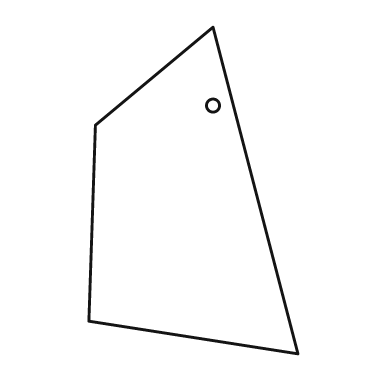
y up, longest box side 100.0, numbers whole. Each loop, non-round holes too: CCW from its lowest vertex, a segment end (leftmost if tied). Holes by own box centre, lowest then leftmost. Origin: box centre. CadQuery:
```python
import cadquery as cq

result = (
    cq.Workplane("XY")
    .moveTo(32.0, -50.0)
    .lineTo(6.0, 50.0)
    .lineTo(-30.0, 20.0)
    .lineTo(-32.0, -40.0)
    .close()
    .moveTo(6.0, 26.0)
    .circle(2.0)
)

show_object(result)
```